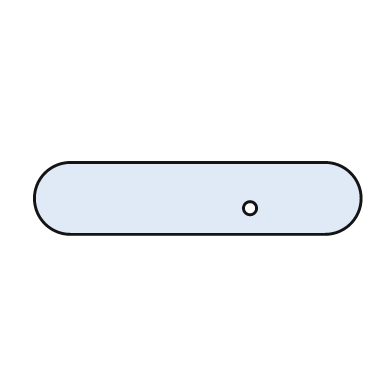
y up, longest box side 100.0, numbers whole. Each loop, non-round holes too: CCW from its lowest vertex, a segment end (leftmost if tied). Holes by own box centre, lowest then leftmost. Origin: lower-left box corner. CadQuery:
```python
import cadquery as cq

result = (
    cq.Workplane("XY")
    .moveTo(11.0, 0.0)
    .lineTo(89.0, 0.0)
    .threePointArc((100.0, 11.0), (89.0, 22.0))
    .lineTo(11.0, 22.0)
    .threePointArc((0.0, 11.0), (11.0, 0.0))
    .close()
    .moveTo(66.0, 8.0)
    .circle(2.0)
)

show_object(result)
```